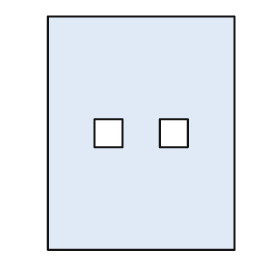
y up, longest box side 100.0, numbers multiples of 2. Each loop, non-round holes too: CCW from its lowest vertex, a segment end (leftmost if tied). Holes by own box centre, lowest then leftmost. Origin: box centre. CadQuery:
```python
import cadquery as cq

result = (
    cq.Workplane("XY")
    .moveTo(-40.0, -50.0)
    .lineTo(40.0, -50.0)
    .lineTo(40.0, 50.0)
    .lineTo(-40.0, 50.0)
    .close()
    .moveTo(-20.0, -6.0)
    .lineTo(-8.0, -6.0)
    .lineTo(-8.0, 6.0)
    .lineTo(-20.0, 6.0)
    .close()
    .moveTo(8.0, -6.0)
    .lineTo(20.0, -6.0)
    .lineTo(20.0, 6.0)
    .lineTo(8.0, 6.0)
    .close()
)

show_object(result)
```